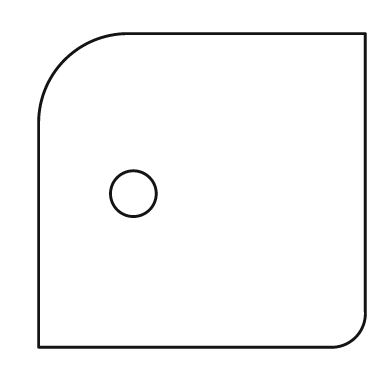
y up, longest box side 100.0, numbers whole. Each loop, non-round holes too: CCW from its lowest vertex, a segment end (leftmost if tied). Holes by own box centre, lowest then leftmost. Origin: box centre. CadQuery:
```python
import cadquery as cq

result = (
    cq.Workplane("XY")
    .moveTo(-50.0, -48.0)
    .lineTo(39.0, -48.0)
    .threePointArc((47.0, -45.0), (50.0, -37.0))
    .lineTo(50.0, 48.0)
    .lineTo(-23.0, 48.0)
    .threePointArc((-42.0, 40.0), (-50.0, 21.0))
    .close()
    .moveTo(-21.0, -1.0)
    .circle(7.0)
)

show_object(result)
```